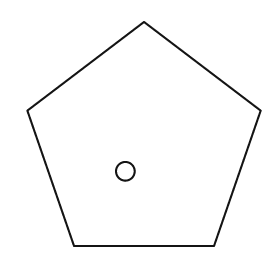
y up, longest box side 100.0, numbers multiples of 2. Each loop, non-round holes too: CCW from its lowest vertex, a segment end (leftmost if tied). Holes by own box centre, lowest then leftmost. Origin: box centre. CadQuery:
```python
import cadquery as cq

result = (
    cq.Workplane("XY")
    .moveTo(-30.0, -48.0)
    .lineTo(30.0, -48.0)
    .lineTo(50.0, 10.0)
    .lineTo(0.0, 48.0)
    .lineTo(-50.0, 10.0)
    .close()
    .moveTo(-8.0, -16.0)
    .circle(4.0)
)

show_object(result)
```